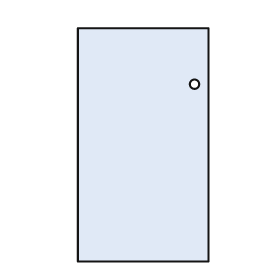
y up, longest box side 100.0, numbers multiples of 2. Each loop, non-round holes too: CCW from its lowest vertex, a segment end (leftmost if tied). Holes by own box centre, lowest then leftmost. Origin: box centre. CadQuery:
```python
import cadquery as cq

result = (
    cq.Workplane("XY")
    .moveTo(-28.0, -50.0)
    .lineTo(28.0, -50.0)
    .lineTo(28.0, 50.0)
    .lineTo(-28.0, 50.0)
    .close()
    .moveTo(22.0, 26.0)
    .circle(2.0)
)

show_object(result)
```